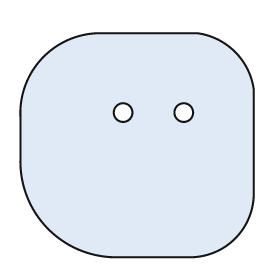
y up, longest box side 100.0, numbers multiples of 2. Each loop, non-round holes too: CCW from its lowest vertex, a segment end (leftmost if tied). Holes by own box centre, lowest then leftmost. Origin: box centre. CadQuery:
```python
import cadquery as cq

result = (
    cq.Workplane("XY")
    .moveTo(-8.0, -48.0)
    .lineTo(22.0, -48.0)
    .threePointArc((42.0, -40.0), (50.0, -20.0))
    .lineTo(50.0, 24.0)
    .threePointArc((42.0, 40.0), (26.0, 48.0))
    .lineTo(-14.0, 48.0)
    .threePointArc((-40.0, 38.0), (-50.0, 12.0))
    .lineTo(-50.0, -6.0)
    .threePointArc((-38.0, -36.0), (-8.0, -48.0))
    .close()
    .moveTo(-6.0, 14.0)
    .circle(4.0)
    .moveTo(20.0, 14.0)
    .circle(4.0)
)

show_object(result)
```